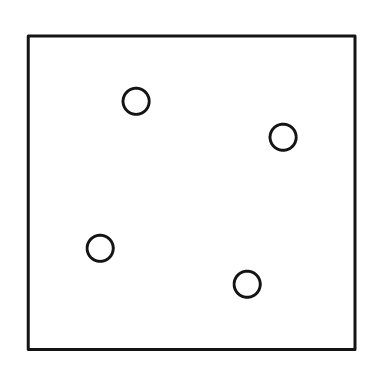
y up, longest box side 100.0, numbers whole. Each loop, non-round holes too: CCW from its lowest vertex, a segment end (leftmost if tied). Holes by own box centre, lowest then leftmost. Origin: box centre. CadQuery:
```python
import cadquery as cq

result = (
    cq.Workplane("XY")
    .moveTo(-50.0, -48.0)
    .lineTo(50.0, -48.0)
    .lineTo(50.0, 48.0)
    .lineTo(-50.0, 48.0)
    .close()
    .moveTo(17.0, -28.0)
    .circle(4.0)
    .moveTo(-28.0, -17.0)
    .circle(4.0)
    .moveTo(28.0, 17.0)
    .circle(4.0)
    .moveTo(-17.0, 28.0)
    .circle(4.0)
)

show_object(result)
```